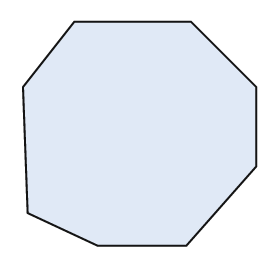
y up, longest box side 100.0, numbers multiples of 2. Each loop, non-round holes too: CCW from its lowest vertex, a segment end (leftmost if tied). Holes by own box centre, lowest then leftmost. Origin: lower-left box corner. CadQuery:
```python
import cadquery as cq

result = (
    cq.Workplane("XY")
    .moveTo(32.0, 0.0)
    .lineTo(70.0, 0.0)
    .lineTo(100.0, 34.0)
    .lineTo(100.0, 68.0)
    .lineTo(72.0, 96.0)
    .lineTo(22.0, 96.0)
    .lineTo(0.0, 68.0)
    .lineTo(2.0, 14.0)
    .close()
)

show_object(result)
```